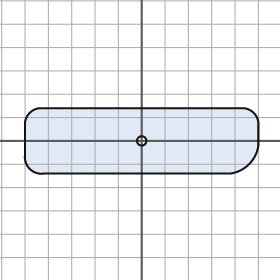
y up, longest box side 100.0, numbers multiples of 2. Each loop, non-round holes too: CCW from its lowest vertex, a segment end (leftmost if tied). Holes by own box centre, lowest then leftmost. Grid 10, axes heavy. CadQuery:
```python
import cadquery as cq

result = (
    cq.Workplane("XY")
    .moveTo(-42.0, -14.0)
    .lineTo(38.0, -14.0)
    .threePointArc((46.0, -10.0), (50.0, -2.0))
    .lineTo(50.0, 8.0)
    .threePointArc((48.0, 12.0), (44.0, 14.0))
    .lineTo(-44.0, 14.0)
    .threePointArc((-48.0, 12.0), (-50.0, 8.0))
    .lineTo(-50.0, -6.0)
    .threePointArc((-48.0, -12.0), (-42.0, -14.0))
    .close()
    .moveTo(0.0, 0.0)
    .circle(2.0)
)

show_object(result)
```